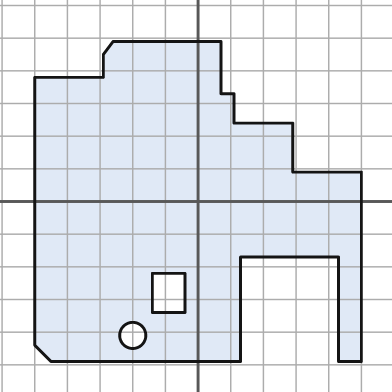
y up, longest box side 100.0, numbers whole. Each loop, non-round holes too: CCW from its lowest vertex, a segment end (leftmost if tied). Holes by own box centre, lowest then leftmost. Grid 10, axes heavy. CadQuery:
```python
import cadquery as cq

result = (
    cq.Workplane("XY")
    .moveTo(-45.0, -49.0)
    .lineTo(13.0, -49.0)
    .lineTo(13.0, -17.0)
    .lineTo(43.0, -17.0)
    .lineTo(43.0, -49.0)
    .lineTo(50.0, -49.0)
    .lineTo(50.0, 9.0)
    .lineTo(29.0, 9.0)
    .lineTo(29.0, 24.0)
    .lineTo(11.0, 24.0)
    .lineTo(11.0, 33.0)
    .lineTo(7.0, 33.0)
    .lineTo(7.0, 49.0)
    .lineTo(-26.0, 49.0)
    .lineTo(-29.0, 45.0)
    .lineTo(-29.0, 38.0)
    .lineTo(-50.0, 38.0)
    .lineTo(-50.0, -44.0)
    .close()
    .moveTo(-20.0, -41.0)
    .circle(4.0)
    .moveTo(-14.0, -34.0)
    .lineTo(-4.0, -34.0)
    .lineTo(-4.0, -22.0)
    .lineTo(-14.0, -22.0)
    .close()
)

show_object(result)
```